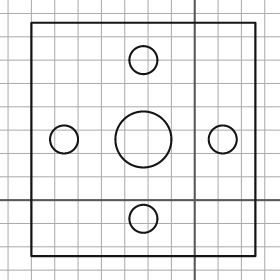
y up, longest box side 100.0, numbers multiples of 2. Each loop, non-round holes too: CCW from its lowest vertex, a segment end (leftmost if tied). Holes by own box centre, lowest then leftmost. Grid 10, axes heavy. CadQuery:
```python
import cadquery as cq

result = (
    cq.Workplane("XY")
    .moveTo(-70.0, -24.0)
    .lineTo(26.0, -24.0)
    .lineTo(26.0, 76.0)
    .lineTo(-70.0, 76.0)
    .close()
    .moveTo(-22.0, -8.0)
    .circle(6.0)
    .moveTo(-56.0, 26.0)
    .circle(6.0)
    .moveTo(-22.0, 26.0)
    .circle(12.0)
    .moveTo(12.0, 26.0)
    .circle(6.0)
    .moveTo(-22.0, 60.0)
    .circle(6.0)
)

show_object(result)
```